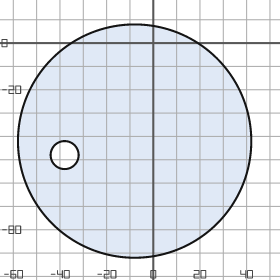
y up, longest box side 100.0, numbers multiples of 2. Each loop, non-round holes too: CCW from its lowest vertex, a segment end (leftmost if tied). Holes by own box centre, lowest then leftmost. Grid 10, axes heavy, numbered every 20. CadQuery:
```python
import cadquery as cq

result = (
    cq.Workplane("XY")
    .moveTo(-8.0, -42.0)
    .circle(50.0)
    .moveTo(-38.0, -48.0)
    .circle(6.0)
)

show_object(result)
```